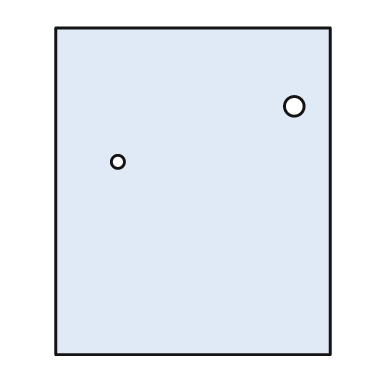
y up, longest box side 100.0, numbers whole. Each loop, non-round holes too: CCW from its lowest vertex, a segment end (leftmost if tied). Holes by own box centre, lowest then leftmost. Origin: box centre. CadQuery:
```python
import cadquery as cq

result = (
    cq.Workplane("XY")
    .moveTo(-42.0, -50.0)
    .lineTo(42.0, -50.0)
    .lineTo(42.0, 50.0)
    .lineTo(-42.0, 50.0)
    .close()
    .moveTo(-23.0, 9.0)
    .circle(2.0)
    .moveTo(31.0, 26.0)
    .circle(3.0)
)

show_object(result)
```